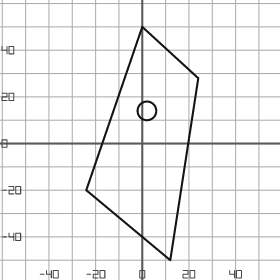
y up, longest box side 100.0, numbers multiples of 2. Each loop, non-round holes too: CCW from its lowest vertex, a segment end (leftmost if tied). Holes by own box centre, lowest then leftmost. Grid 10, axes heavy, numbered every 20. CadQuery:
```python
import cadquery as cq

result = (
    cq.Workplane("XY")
    .moveTo(12.0, -50.0)
    .lineTo(24.0, 28.0)
    .lineTo(0.0, 50.0)
    .lineTo(-24.0, -20.0)
    .close()
    .moveTo(2.0, 14.0)
    .circle(4.0)
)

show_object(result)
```